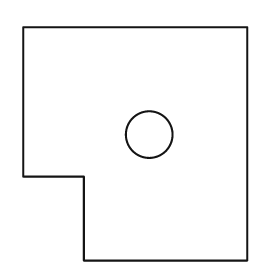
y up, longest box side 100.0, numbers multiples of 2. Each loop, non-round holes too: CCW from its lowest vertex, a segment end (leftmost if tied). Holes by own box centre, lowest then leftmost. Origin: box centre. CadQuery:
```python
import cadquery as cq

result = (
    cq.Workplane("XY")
    .moveTo(-22.0, -50.0)
    .lineTo(48.0, -50.0)
    .lineTo(48.0, 50.0)
    .lineTo(-48.0, 50.0)
    .lineTo(-48.0, -14.0)
    .lineTo(-22.0, -14.0)
    .close()
    .moveTo(6.0, 4.0)
    .circle(10.0)
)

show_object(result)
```